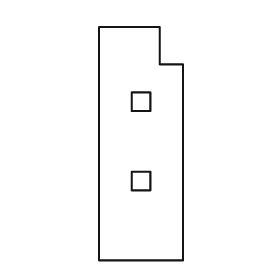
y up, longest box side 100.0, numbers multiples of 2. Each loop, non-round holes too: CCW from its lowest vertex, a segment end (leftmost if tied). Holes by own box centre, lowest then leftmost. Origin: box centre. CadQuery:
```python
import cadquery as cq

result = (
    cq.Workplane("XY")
    .moveTo(-18.0, -50.0)
    .lineTo(18.0, -50.0)
    .lineTo(18.0, 34.0)
    .lineTo(8.0, 34.0)
    .lineTo(8.0, 50.0)
    .lineTo(-18.0, 50.0)
    .close()
    .moveTo(-4.0, -20.0)
    .lineTo(4.0, -20.0)
    .lineTo(4.0, -12.0)
    .lineTo(-4.0, -12.0)
    .close()
    .moveTo(-4.0, 14.0)
    .lineTo(4.0, 14.0)
    .lineTo(4.0, 22.0)
    .lineTo(-4.0, 22.0)
    .close()
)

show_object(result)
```